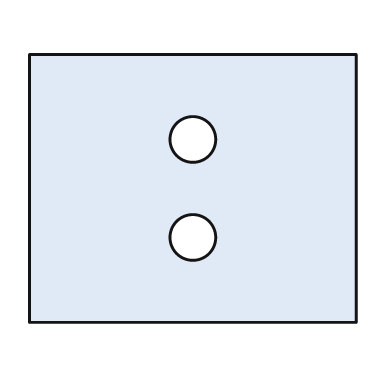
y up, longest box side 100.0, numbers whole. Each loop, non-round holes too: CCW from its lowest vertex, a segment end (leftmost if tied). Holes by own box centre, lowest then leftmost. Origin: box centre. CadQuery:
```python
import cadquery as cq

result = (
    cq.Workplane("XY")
    .moveTo(-50.0, -41.0)
    .lineTo(50.0, -41.0)
    .lineTo(50.0, 41.0)
    .lineTo(-50.0, 41.0)
    .close()
    .moveTo(0.0, -15.0)
    .circle(7.0)
    .moveTo(0.0, 15.0)
    .circle(7.0)
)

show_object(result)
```